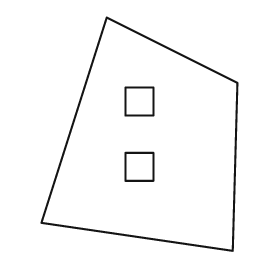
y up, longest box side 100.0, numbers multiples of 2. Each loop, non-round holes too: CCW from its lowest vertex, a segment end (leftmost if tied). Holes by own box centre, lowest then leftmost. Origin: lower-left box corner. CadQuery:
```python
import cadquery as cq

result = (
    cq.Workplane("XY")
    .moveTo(82.0, 0.0)
    .lineTo(84.0, 72.0)
    .lineTo(28.0, 100.0)
    .lineTo(0.0, 12.0)
    .close()
    .moveTo(36.0, 30.0)
    .lineTo(48.0, 30.0)
    .lineTo(48.0, 42.0)
    .lineTo(36.0, 42.0)
    .close()
    .moveTo(36.0, 58.0)
    .lineTo(48.0, 58.0)
    .lineTo(48.0, 70.0)
    .lineTo(36.0, 70.0)
    .close()
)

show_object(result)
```